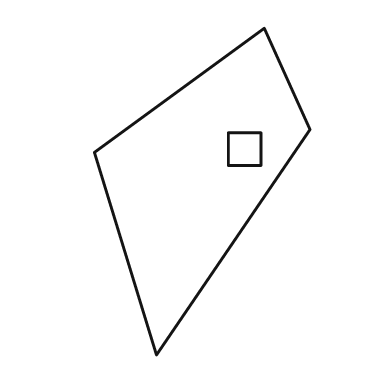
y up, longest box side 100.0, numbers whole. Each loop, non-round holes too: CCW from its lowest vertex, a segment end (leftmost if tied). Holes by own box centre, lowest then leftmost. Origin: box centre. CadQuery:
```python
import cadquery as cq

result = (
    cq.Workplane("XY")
    .moveTo(-14.0, -50.0)
    .lineTo(33.0, 19.0)
    .lineTo(19.0, 50.0)
    .lineTo(-33.0, 12.0)
    .close()
    .moveTo(8.0, 8.0)
    .lineTo(18.0, 8.0)
    .lineTo(18.0, 18.0)
    .lineTo(8.0, 18.0)
    .close()
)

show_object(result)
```